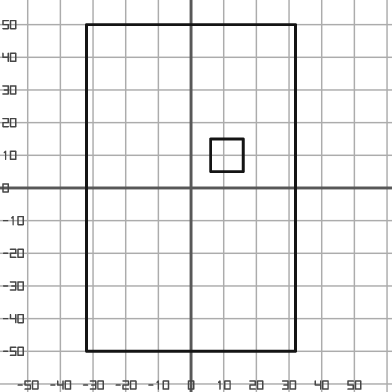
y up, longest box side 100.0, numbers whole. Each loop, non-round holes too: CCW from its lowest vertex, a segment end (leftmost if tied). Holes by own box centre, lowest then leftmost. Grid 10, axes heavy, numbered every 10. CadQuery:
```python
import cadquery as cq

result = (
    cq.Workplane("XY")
    .moveTo(-32.0, -50.0)
    .lineTo(32.0, -50.0)
    .lineTo(32.0, 50.0)
    .lineTo(-32.0, 50.0)
    .close()
    .moveTo(6.0, 5.0)
    .lineTo(16.0, 5.0)
    .lineTo(16.0, 15.0)
    .lineTo(6.0, 15.0)
    .close()
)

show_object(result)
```